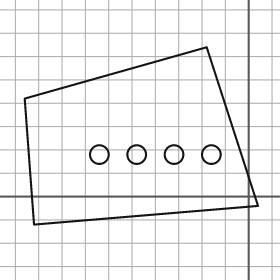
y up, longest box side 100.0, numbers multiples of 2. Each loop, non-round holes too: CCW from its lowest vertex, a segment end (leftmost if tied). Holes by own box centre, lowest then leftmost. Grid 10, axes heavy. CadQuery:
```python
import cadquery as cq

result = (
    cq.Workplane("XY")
    .moveTo(-92.0, -12.0)
    .lineTo(4.0, -4.0)
    .lineTo(-18.0, 64.0)
    .lineTo(-96.0, 42.0)
    .close()
    .moveTo(-64.0, 18.0)
    .circle(4.0)
    .moveTo(-48.0, 18.0)
    .circle(4.0)
    .moveTo(-32.0, 18.0)
    .circle(4.0)
    .moveTo(-16.0, 18.0)
    .circle(4.0)
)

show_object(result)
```